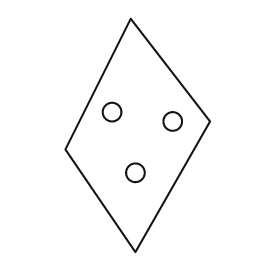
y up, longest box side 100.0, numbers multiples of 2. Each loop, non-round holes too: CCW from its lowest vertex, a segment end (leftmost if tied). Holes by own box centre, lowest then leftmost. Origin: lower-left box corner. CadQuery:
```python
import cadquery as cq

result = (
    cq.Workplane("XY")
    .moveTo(30.0, 0.0)
    .lineTo(62.0, 56.0)
    .lineTo(28.0, 100.0)
    .lineTo(0.0, 44.0)
    .close()
    .moveTo(30.0, 34.0)
    .circle(4.0)
    .moveTo(46.0, 56.0)
    .circle(4.0)
    .moveTo(20.0, 60.0)
    .circle(4.0)
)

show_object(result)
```